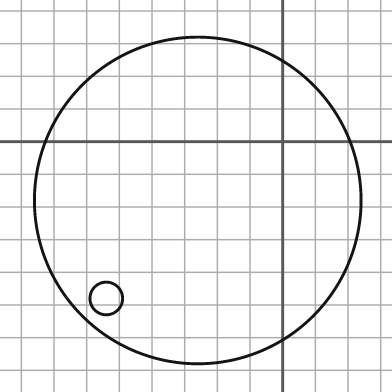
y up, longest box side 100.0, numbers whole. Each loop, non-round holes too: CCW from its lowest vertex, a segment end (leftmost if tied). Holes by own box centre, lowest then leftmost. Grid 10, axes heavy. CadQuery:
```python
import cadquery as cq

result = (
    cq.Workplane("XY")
    .moveTo(-26.0, -18.0)
    .circle(50.0)
    .moveTo(-54.0, -48.0)
    .circle(5.0)
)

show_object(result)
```